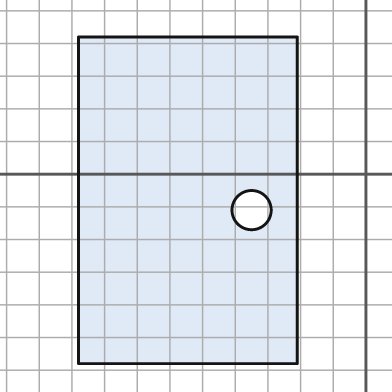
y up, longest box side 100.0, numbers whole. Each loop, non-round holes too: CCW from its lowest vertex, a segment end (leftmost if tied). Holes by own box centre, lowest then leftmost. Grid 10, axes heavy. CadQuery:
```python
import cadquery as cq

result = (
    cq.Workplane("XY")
    .moveTo(-88.0, -58.0)
    .lineTo(-21.0, -58.0)
    .lineTo(-21.0, 42.0)
    .lineTo(-88.0, 42.0)
    .close()
    .moveTo(-35.0, -11.0)
    .circle(6.0)
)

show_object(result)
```